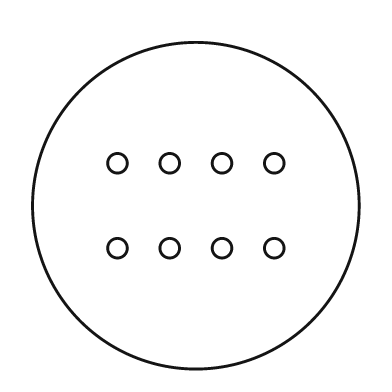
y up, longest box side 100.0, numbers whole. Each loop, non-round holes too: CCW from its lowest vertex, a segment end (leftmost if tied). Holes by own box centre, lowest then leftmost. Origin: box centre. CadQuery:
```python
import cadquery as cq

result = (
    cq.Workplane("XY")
    .moveTo(0.0, 0.0)
    .circle(50.0)
    .moveTo(-24.0, -13.0)
    .circle(3.0)
    .moveTo(-8.0, -13.0)
    .circle(3.0)
    .moveTo(8.0, -13.0)
    .circle(3.0)
    .moveTo(24.0, -13.0)
    .circle(3.0)
    .moveTo(-24.0, 13.0)
    .circle(3.0)
    .moveTo(-8.0, 13.0)
    .circle(3.0)
    .moveTo(8.0, 13.0)
    .circle(3.0)
    .moveTo(24.0, 13.0)
    .circle(3.0)
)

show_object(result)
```